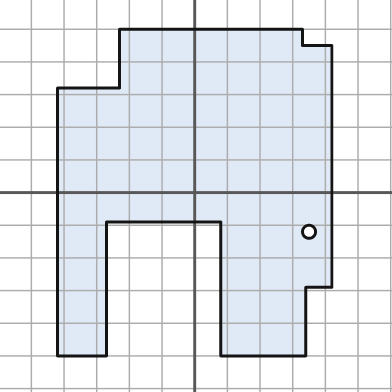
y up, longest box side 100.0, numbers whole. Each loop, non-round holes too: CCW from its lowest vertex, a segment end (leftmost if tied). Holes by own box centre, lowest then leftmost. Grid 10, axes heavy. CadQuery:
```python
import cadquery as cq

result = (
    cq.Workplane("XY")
    .moveTo(-42.0, -50.0)
    .lineTo(-27.0, -50.0)
    .lineTo(-27.0, -9.0)
    .lineTo(8.0, -9.0)
    .lineTo(8.0, -50.0)
    .lineTo(34.0, -50.0)
    .lineTo(34.0, -29.0)
    .lineTo(42.0, -29.0)
    .lineTo(42.0, 45.0)
    .lineTo(33.0, 45.0)
    .lineTo(33.0, 50.0)
    .lineTo(-23.0, 50.0)
    .lineTo(-23.0, 32.0)
    .lineTo(-42.0, 32.0)
    .close()
    .moveTo(35.0, -12.0)
    .circle(2.0)
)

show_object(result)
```